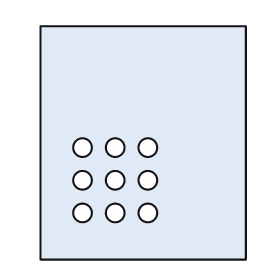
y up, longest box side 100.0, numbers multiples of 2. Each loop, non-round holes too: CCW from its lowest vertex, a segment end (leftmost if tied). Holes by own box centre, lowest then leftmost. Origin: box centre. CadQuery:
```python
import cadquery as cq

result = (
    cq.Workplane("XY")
    .moveTo(-44.0, -50.0)
    .lineTo(44.0, -50.0)
    .lineTo(44.0, 50.0)
    .lineTo(-44.0, 50.0)
    .close()
    .moveTo(-26.0, -30.0)
    .circle(4.0)
    .moveTo(-12.0, -30.0)
    .circle(4.0)
    .moveTo(2.0, -30.0)
    .circle(4.0)
    .moveTo(-26.0, -16.0)
    .circle(4.0)
    .moveTo(-12.0, -16.0)
    .circle(4.0)
    .moveTo(2.0, -16.0)
    .circle(4.0)
    .moveTo(-26.0, -2.0)
    .circle(4.0)
    .moveTo(-12.0, -2.0)
    .circle(4.0)
    .moveTo(2.0, -2.0)
    .circle(4.0)
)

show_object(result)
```